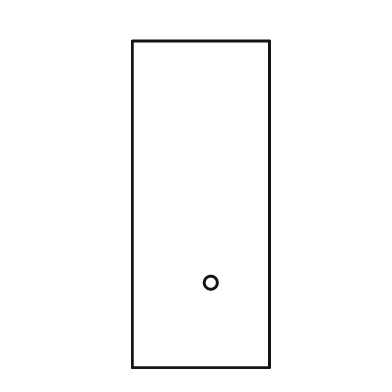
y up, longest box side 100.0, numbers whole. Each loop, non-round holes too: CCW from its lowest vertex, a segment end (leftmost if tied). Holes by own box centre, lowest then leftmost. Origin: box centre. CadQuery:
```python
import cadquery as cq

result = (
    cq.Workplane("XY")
    .moveTo(-21.0, -50.0)
    .lineTo(21.0, -50.0)
    .lineTo(21.0, 50.0)
    .lineTo(-21.0, 50.0)
    .close()
    .moveTo(3.0, -24.0)
    .circle(2.0)
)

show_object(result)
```